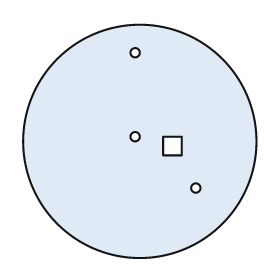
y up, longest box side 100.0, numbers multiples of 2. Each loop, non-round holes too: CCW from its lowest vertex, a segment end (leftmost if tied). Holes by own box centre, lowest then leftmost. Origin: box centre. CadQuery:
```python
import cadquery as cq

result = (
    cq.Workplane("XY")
    .moveTo(0.0, 0.0)
    .circle(50.0)
    .moveTo(24.0, -20.0)
    .circle(2.0)
    .moveTo(10.0, -6.0)
    .lineTo(18.0, -6.0)
    .lineTo(18.0, 2.0)
    .lineTo(10.0, 2.0)
    .close()
    .moveTo(-2.0, 2.0)
    .circle(2.0)
    .moveTo(-2.0, 38.0)
    .circle(2.0)
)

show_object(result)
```